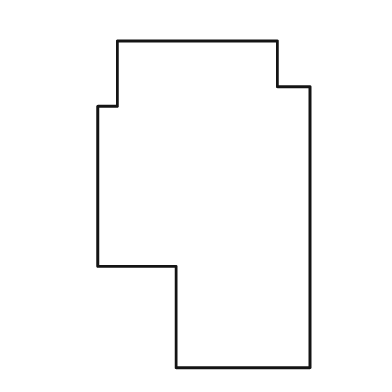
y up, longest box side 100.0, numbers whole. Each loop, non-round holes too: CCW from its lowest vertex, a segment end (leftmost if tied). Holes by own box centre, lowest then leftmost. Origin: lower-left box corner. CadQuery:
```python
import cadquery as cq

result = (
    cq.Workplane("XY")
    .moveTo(24.0, 0.0)
    .lineTo(65.0, 0.0)
    .lineTo(65.0, 86.0)
    .lineTo(55.0, 86.0)
    .lineTo(55.0, 100.0)
    .lineTo(6.0, 100.0)
    .lineTo(6.0, 80.0)
    .lineTo(0.0, 80.0)
    .lineTo(0.0, 31.0)
    .lineTo(24.0, 31.0)
    .close()
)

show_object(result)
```